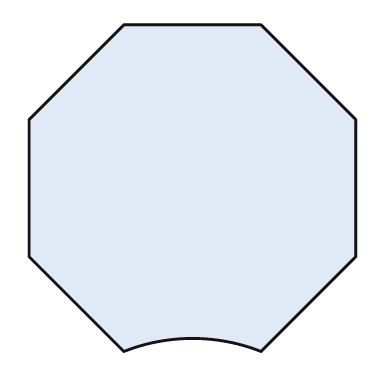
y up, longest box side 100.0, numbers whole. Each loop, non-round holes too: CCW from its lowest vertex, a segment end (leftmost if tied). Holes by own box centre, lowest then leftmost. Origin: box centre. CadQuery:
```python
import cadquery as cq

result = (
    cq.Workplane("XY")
    .moveTo(-21.0, -50.0)
    .threePointArc((0.0, -46.0), (21.0, -50.0))
    .lineTo(50.0, -21.0)
    .lineTo(50.0, 21.0)
    .lineTo(21.0, 50.0)
    .lineTo(-21.0, 50.0)
    .lineTo(-50.0, 21.0)
    .lineTo(-50.0, -21.0)
    .close()
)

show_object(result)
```